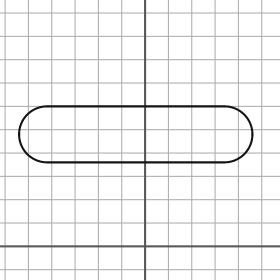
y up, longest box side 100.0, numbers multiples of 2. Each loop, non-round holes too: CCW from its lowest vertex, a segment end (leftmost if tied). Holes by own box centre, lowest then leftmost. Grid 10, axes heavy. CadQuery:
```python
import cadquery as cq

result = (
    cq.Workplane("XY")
    .moveTo(-42.0, 36.0)
    .lineTo(34.0, 36.0)
    .threePointArc((46.0, 48.0), (34.0, 60.0))
    .lineTo(-42.0, 60.0)
    .threePointArc((-54.0, 48.0), (-42.0, 36.0))
    .close()
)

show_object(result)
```